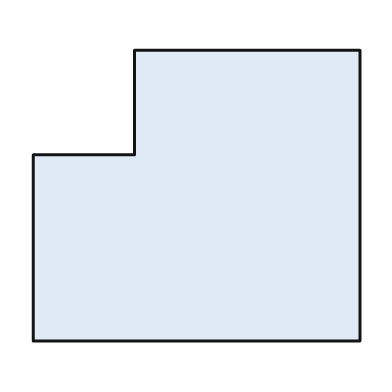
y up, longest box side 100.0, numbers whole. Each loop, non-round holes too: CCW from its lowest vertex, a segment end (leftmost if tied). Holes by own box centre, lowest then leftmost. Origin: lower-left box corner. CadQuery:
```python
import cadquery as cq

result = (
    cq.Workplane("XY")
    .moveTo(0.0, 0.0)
    .lineTo(100.0, 0.0)
    .lineTo(100.0, 89.0)
    .lineTo(31.0, 89.0)
    .lineTo(31.0, 57.0)
    .lineTo(0.0, 57.0)
    .close()
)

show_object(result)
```